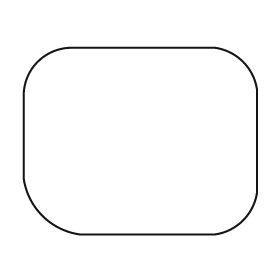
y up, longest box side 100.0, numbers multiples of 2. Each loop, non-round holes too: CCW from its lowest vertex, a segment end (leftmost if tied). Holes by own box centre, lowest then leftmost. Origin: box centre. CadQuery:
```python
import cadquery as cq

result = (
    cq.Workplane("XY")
    .moveTo(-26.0, -40.0)
    .lineTo(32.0, -40.0)
    .threePointArc((44.0, -34.0), (50.0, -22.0))
    .lineTo(50.0, 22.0)
    .threePointArc((44.0, 34.0), (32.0, 40.0))
    .lineTo(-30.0, 40.0)
    .threePointArc((-44.0, 34.0), (-50.0, 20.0))
    .lineTo(-50.0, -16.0)
    .threePointArc((-42.0, -32.0), (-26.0, -40.0))
    .close()
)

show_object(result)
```